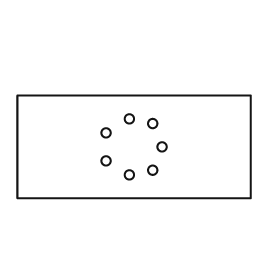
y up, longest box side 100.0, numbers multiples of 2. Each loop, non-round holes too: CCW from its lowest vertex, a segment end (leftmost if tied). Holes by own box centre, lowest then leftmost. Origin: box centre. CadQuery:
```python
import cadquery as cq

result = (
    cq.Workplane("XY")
    .moveTo(-50.0, -22.0)
    .lineTo(50.0, -22.0)
    .lineTo(50.0, 22.0)
    .lineTo(-50.0, 22.0)
    .close()
    .moveTo(-2.0, -12.0)
    .circle(2.0)
    .moveTo(8.0, -10.0)
    .circle(2.0)
    .moveTo(-12.0, -6.0)
    .circle(2.0)
    .moveTo(12.0, 0.0)
    .circle(2.0)
    .moveTo(-12.0, 6.0)
    .circle(2.0)
    .moveTo(8.0, 10.0)
    .circle(2.0)
    .moveTo(-2.0, 12.0)
    .circle(2.0)
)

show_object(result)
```